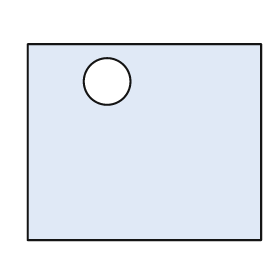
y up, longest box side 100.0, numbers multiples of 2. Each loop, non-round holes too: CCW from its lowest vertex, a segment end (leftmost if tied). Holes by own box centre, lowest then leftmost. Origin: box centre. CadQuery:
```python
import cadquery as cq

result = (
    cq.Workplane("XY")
    .moveTo(-50.0, -42.0)
    .lineTo(50.0, -42.0)
    .lineTo(50.0, 42.0)
    .lineTo(-50.0, 42.0)
    .close()
    .moveTo(-16.0, 26.0)
    .circle(10.0)
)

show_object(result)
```